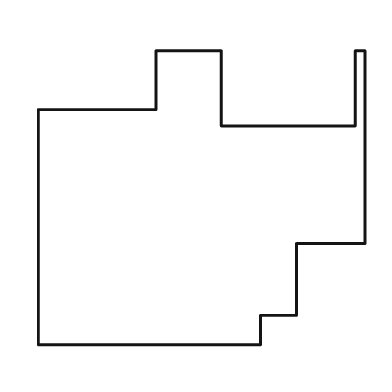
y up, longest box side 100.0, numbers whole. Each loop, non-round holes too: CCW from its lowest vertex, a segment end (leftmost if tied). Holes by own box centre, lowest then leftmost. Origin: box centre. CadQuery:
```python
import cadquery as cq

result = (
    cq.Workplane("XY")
    .moveTo(-50.0, -45.0)
    .lineTo(18.0, -45.0)
    .lineTo(18.0, -36.0)
    .lineTo(29.0, -36.0)
    .lineTo(29.0, -14.0)
    .lineTo(50.0, -14.0)
    .lineTo(50.0, 45.0)
    .lineTo(47.0, 45.0)
    .lineTo(47.0, 22.0)
    .lineTo(6.0, 22.0)
    .lineTo(6.0, 45.0)
    .lineTo(-14.0, 45.0)
    .lineTo(-14.0, 27.0)
    .lineTo(-50.0, 27.0)
    .close()
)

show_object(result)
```